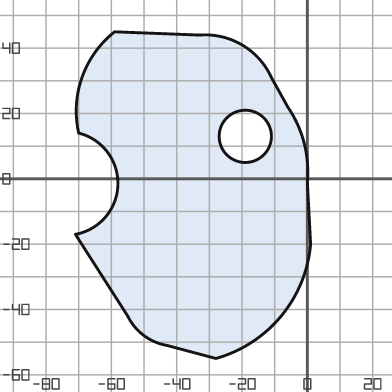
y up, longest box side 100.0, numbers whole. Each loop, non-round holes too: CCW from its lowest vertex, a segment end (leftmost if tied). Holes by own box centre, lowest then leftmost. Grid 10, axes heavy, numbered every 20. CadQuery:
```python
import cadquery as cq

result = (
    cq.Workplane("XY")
    .moveTo(-28.0, -55.0)
    .threePointArc((-8.0, -42.0), (1.0, -20.0))
    .lineTo(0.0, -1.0)
    .threePointArc((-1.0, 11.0), (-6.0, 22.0))
    .lineTo(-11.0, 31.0)
    .threePointArc((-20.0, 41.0), (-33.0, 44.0))
    .lineTo(-59.0, 45.0)
    .threePointArc((-69.0, 31.0), (-70.0, 14.0))
    .threePointArc((-58.0, -2.0), (-71.0, -17.0))
    .lineTo(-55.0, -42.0)
    .threePointArc((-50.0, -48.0), (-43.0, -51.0))
    .close()
    .moveTo(-19.0, 13.0)
    .circle(8.0)
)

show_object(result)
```